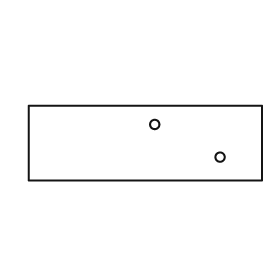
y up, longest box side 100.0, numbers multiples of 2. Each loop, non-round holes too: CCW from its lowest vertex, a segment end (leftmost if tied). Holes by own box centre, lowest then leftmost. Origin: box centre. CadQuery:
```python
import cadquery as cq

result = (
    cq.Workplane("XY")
    .moveTo(-50.0, -16.0)
    .lineTo(50.0, -16.0)
    .lineTo(50.0, 16.0)
    .lineTo(-50.0, 16.0)
    .close()
    .moveTo(32.0, -6.0)
    .circle(2.0)
    .moveTo(4.0, 8.0)
    .circle(2.0)
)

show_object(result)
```